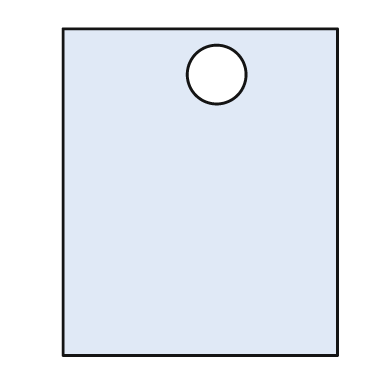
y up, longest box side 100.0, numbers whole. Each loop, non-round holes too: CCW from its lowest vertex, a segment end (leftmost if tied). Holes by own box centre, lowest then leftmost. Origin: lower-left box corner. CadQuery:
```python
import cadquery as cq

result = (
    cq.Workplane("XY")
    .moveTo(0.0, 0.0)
    .lineTo(84.0, 0.0)
    .lineTo(84.0, 100.0)
    .lineTo(0.0, 100.0)
    .close()
    .moveTo(47.0, 86.0)
    .circle(9.0)
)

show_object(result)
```